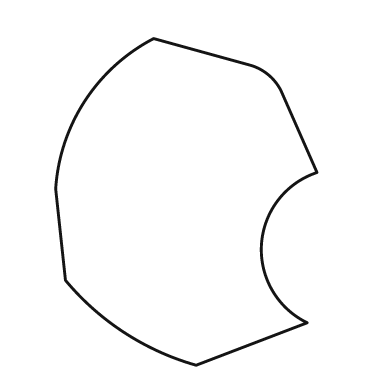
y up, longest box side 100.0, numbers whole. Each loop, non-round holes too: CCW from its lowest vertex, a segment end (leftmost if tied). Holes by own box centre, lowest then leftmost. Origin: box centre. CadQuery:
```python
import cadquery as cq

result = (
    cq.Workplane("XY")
    .moveTo(3.0, -50.0)
    .lineTo(37.0, -37.0)
    .threePointArc((23.0, -13.0), (40.0, 9.0))
    .lineTo(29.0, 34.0)
    .threePointArc((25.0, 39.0), (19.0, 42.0))
    .lineTo(-10.0, 50.0)
    .threePointArc((-31.0, 31.0), (-40.0, 4.0))
    .lineTo(-37.0, -24.0)
    .threePointArc((-19.0, -40.0), (3.0, -50.0))
    .close()
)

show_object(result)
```